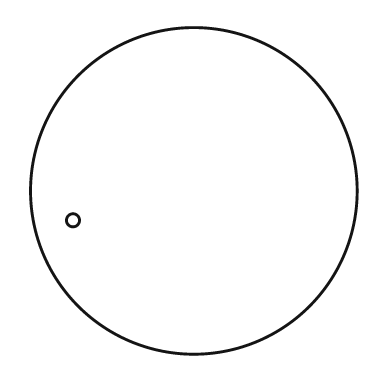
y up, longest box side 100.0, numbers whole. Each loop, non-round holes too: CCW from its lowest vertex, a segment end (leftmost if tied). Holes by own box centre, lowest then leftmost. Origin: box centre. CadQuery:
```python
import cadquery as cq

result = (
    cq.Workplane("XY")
    .moveTo(0.0, 0.0)
    .circle(50.0)
    .moveTo(-37.0, -9.0)
    .circle(2.0)
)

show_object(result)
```